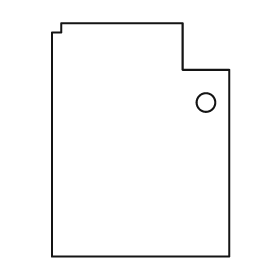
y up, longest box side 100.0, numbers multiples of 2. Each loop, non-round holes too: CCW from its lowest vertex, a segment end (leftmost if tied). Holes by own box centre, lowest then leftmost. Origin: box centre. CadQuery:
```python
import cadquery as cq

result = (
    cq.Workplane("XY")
    .moveTo(-38.0, -50.0)
    .lineTo(38.0, -50.0)
    .lineTo(38.0, 30.0)
    .lineTo(18.0, 30.0)
    .lineTo(18.0, 50.0)
    .lineTo(-34.0, 50.0)
    .lineTo(-34.0, 46.0)
    .lineTo(-38.0, 46.0)
    .close()
    .moveTo(28.0, 16.0)
    .circle(4.0)
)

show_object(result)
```